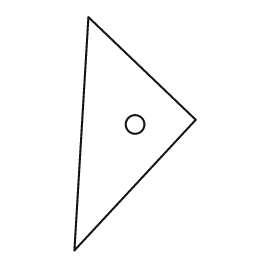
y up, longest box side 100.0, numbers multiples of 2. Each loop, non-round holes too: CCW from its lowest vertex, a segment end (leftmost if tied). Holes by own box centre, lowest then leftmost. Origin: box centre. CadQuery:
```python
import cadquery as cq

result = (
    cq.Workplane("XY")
    .moveTo(-26.0, -50.0)
    .lineTo(26.0, 6.0)
    .lineTo(-20.0, 50.0)
    .close()
    .moveTo(0.0, 4.0)
    .circle(4.0)
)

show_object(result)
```